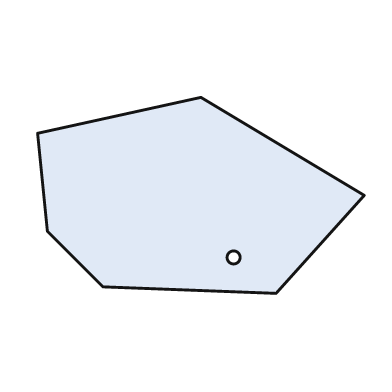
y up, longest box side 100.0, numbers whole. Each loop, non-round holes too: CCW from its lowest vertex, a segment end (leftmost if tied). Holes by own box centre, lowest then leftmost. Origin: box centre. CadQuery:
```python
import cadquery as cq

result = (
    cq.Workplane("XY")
    .moveTo(23.0, -30.0)
    .lineTo(50.0, 0.0)
    .lineTo(0.0, 30.0)
    .lineTo(-50.0, 19.0)
    .lineTo(-47.0, -11.0)
    .lineTo(-30.0, -28.0)
    .close()
    .moveTo(10.0, -19.0)
    .circle(2.0)
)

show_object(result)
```